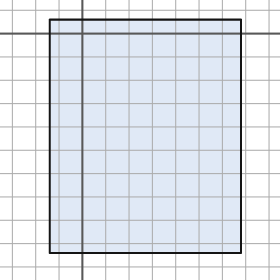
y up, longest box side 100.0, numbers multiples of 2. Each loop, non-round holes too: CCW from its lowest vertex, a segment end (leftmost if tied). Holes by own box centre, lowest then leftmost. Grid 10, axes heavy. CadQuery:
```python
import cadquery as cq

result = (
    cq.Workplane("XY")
    .moveTo(-14.0, -94.0)
    .lineTo(68.0, -94.0)
    .lineTo(68.0, 6.0)
    .lineTo(-14.0, 6.0)
    .close()
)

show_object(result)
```